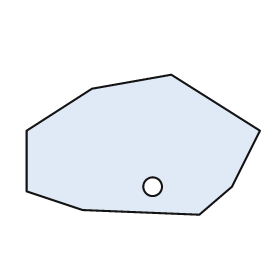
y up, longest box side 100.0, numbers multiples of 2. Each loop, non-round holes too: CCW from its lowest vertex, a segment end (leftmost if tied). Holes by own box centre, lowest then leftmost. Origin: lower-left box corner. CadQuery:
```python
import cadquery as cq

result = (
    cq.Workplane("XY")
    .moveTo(74.0, 0.0)
    .lineTo(88.0, 12.0)
    .lineTo(100.0, 36.0)
    .lineTo(62.0, 60.0)
    .lineTo(28.0, 54.0)
    .lineTo(0.0, 36.0)
    .lineTo(0.0, 10.0)
    .lineTo(24.0, 2.0)
    .close()
    .moveTo(54.0, 12.0)
    .circle(4.0)
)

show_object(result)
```